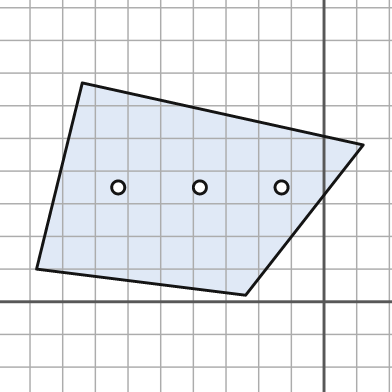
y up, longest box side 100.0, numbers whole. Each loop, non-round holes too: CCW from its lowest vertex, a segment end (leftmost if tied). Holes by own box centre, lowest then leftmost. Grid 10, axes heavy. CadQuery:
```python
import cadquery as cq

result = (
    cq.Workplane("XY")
    .moveTo(-24.0, 2.0)
    .lineTo(12.0, 48.0)
    .lineTo(-74.0, 67.0)
    .lineTo(-88.0, 10.0)
    .close()
    .moveTo(-63.0, 35.0)
    .circle(2.0)
    .moveTo(-38.0, 35.0)
    .circle(2.0)
    .moveTo(-13.0, 35.0)
    .circle(2.0)
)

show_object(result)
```